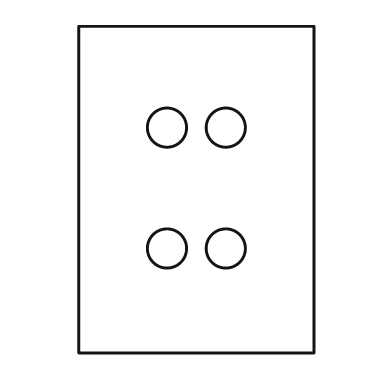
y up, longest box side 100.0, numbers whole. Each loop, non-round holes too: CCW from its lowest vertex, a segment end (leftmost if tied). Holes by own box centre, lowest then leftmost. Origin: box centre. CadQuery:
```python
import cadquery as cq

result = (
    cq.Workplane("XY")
    .moveTo(-36.0, -50.0)
    .lineTo(36.0, -50.0)
    .lineTo(36.0, 50.0)
    .lineTo(-36.0, 50.0)
    .close()
    .moveTo(-9.0, -18.0)
    .circle(6.0)
    .moveTo(9.0, -18.0)
    .circle(6.0)
    .moveTo(-9.0, 19.0)
    .circle(6.0)
    .moveTo(9.0, 19.0)
    .circle(6.0)
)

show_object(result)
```